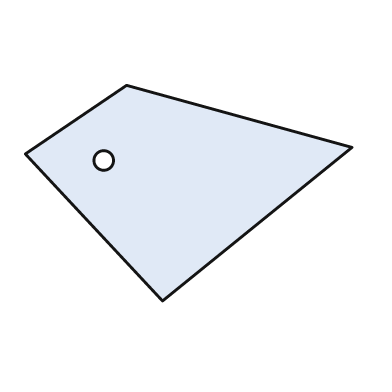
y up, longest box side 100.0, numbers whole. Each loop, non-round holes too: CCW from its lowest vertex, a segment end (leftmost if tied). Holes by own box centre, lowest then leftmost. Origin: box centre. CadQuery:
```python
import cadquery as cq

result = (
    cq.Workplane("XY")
    .moveTo(-8.0, -33.0)
    .lineTo(50.0, 14.0)
    .lineTo(-19.0, 33.0)
    .lineTo(-50.0, 12.0)
    .close()
    .moveTo(-26.0, 10.0)
    .circle(3.0)
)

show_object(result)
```